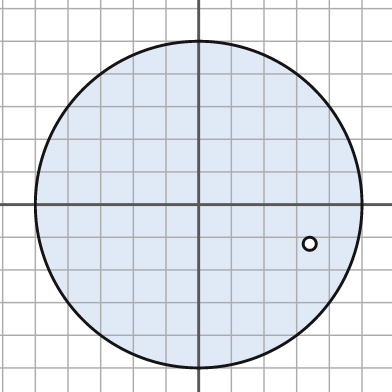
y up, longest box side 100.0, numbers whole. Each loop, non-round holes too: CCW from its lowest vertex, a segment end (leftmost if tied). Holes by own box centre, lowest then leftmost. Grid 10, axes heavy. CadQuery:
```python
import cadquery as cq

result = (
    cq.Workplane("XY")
    .moveTo(0.0, 0.0)
    .circle(50.0)
    .moveTo(34.0, -12.0)
    .circle(2.0)
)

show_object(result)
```